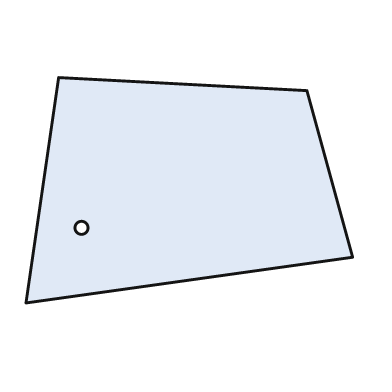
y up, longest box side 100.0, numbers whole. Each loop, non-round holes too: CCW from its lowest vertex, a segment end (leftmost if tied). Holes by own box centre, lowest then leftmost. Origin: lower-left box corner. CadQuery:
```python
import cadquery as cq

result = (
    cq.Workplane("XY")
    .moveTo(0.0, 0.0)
    .lineTo(100.0, 14.0)
    .lineTo(86.0, 65.0)
    .lineTo(10.0, 69.0)
    .close()
    .moveTo(17.0, 23.0)
    .circle(2.0)
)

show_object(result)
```